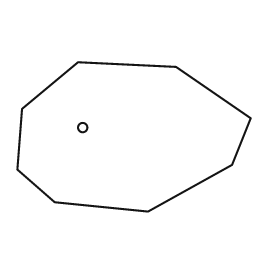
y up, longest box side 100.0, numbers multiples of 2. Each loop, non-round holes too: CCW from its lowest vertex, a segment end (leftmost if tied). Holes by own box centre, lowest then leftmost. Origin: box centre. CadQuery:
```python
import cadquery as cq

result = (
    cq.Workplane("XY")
    .moveTo(6.0, -32.0)
    .lineTo(42.0, -12.0)
    .lineTo(50.0, 8.0)
    .lineTo(18.0, 30.0)
    .lineTo(-24.0, 32.0)
    .lineTo(-48.0, 12.0)
    .lineTo(-50.0, -14.0)
    .lineTo(-34.0, -28.0)
    .close()
    .moveTo(-22.0, 4.0)
    .circle(2.0)
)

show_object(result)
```